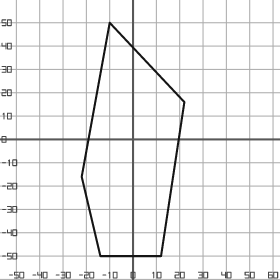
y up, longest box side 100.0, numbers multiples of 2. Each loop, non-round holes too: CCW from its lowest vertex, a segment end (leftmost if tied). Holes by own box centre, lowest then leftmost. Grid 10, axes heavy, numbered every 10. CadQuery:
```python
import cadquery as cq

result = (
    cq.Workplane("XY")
    .moveTo(-14.0, -50.0)
    .lineTo(12.0, -50.0)
    .lineTo(22.0, 16.0)
    .lineTo(-10.0, 50.0)
    .lineTo(-22.0, -16.0)
    .close()
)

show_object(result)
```